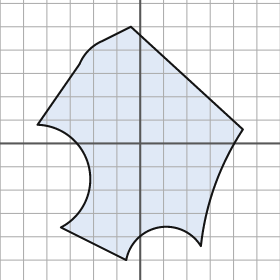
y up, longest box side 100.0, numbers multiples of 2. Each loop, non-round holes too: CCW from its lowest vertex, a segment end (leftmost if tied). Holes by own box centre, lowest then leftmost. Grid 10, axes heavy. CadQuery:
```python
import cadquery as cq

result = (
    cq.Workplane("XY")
    .moveTo(-6.0, -50.0)
    .threePointArc((8.0, -36.0), (26.0, -44.0))
    .threePointArc((32.0, -18.0), (44.0, 6.0))
    .lineTo(-4.0, 50.0)
    .lineTo(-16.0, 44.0)
    .threePointArc((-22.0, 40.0), (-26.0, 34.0))
    .lineTo(-44.0, 8.0)
    .threePointArc((-22.0, -10.0), (-34.0, -36.0))
    .close()
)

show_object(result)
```